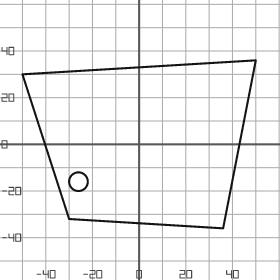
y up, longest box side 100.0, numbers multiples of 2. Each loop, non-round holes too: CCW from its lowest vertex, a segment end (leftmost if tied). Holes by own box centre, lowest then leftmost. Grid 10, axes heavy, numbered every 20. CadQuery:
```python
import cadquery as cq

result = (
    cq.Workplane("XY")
    .moveTo(36.0, -36.0)
    .lineTo(50.0, 36.0)
    .lineTo(-50.0, 30.0)
    .lineTo(-30.0, -32.0)
    .close()
    .moveTo(-26.0, -16.0)
    .circle(4.0)
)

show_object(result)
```